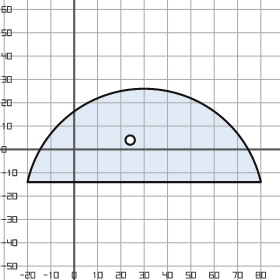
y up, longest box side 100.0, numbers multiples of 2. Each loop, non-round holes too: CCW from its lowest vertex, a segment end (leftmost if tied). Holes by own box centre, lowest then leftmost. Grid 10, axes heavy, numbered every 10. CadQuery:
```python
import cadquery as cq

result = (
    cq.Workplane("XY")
    .moveTo(-20.0, -14.0)
    .lineTo(80.0, -14.0)
    .threePointArc((30.0, 26.0), (-20.0, -14.0))
    .close()
    .moveTo(24.0, 4.0)
    .circle(2.0)
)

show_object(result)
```